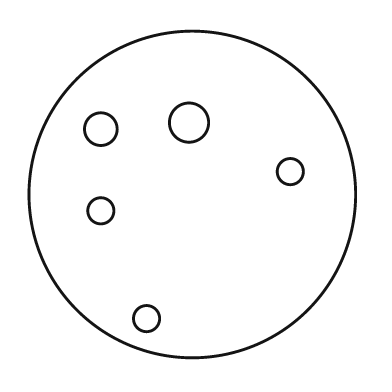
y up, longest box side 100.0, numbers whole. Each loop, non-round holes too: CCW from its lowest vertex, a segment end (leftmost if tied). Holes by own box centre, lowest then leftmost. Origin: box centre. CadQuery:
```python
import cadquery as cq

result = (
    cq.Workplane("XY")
    .moveTo(0.0, 0.0)
    .circle(50.0)
    .moveTo(-14.0, -38.0)
    .circle(4.0)
    .moveTo(-28.0, -5.0)
    .circle(4.0)
    .moveTo(30.0, 7.0)
    .circle(4.0)
    .moveTo(-28.0, 20.0)
    .circle(5.0)
    .moveTo(-1.0, 22.0)
    .circle(6.0)
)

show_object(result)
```